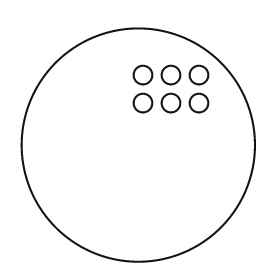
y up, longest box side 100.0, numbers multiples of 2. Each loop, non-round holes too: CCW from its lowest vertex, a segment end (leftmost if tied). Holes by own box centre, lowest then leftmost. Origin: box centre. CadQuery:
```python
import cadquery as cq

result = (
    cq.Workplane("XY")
    .moveTo(0.0, 0.0)
    .circle(50.0)
    .moveTo(2.0, 18.0)
    .circle(4.0)
    .moveTo(14.0, 18.0)
    .circle(4.0)
    .moveTo(26.0, 18.0)
    .circle(4.0)
    .moveTo(2.0, 30.0)
    .circle(4.0)
    .moveTo(14.0, 30.0)
    .circle(4.0)
    .moveTo(26.0, 30.0)
    .circle(4.0)
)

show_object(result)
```